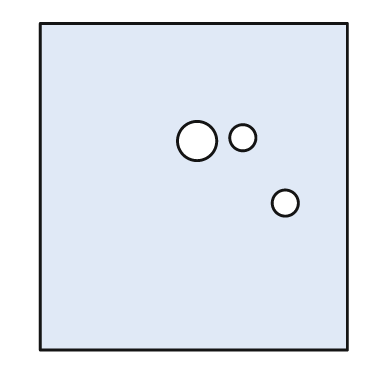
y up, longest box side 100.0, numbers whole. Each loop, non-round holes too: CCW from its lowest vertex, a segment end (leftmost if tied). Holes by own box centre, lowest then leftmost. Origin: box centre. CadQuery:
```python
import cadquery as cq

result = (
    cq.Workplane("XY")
    .moveTo(-47.0, -50.0)
    .lineTo(47.0, -50.0)
    .lineTo(47.0, 50.0)
    .lineTo(-47.0, 50.0)
    .close()
    .moveTo(28.0, -5.0)
    .circle(4.0)
    .moveTo(1.0, 14.0)
    .circle(6.0)
    .moveTo(15.0, 15.0)
    .circle(4.0)
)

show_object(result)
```